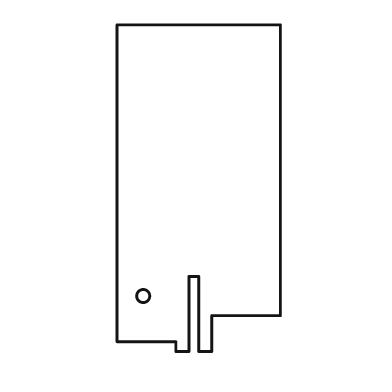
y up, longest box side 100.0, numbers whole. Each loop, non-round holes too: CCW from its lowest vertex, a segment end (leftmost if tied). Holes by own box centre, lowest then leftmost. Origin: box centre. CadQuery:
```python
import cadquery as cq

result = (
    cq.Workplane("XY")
    .moveTo(-7.0, -50.0)
    .lineTo(-3.0, -50.0)
    .lineTo(-3.0, -27.0)
    .lineTo(0.0, -27.0)
    .lineTo(0.0, -50.0)
    .lineTo(4.0, -50.0)
    .lineTo(4.0, -39.0)
    .lineTo(25.0, -39.0)
    .lineTo(25.0, 50.0)
    .lineTo(-25.0, 50.0)
    .lineTo(-25.0, -47.0)
    .lineTo(-7.0, -47.0)
    .close()
    .moveTo(-17.0, -33.0)
    .circle(2.0)
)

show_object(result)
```